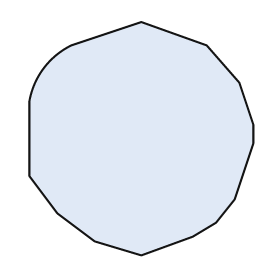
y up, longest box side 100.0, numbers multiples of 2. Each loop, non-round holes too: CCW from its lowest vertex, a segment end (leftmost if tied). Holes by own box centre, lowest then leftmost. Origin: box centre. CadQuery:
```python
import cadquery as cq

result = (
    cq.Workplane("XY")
    .moveTo(0.0, -50.0)
    .lineTo(22.0, -42.0)
    .lineTo(32.0, -36.0)
    .lineTo(40.0, -26.0)
    .lineTo(48.0, -2.0)
    .lineTo(48.0, 6.0)
    .lineTo(42.0, 24.0)
    .lineTo(28.0, 40.0)
    .lineTo(0.0, 50.0)
    .lineTo(-30.0, 40.0)
    .threePointArc((-42.0, 30.0), (-48.0, 16.0))
    .lineTo(-48.0, -16.0)
    .lineTo(-36.0, -32.0)
    .lineTo(-20.0, -44.0)
    .close()
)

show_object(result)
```